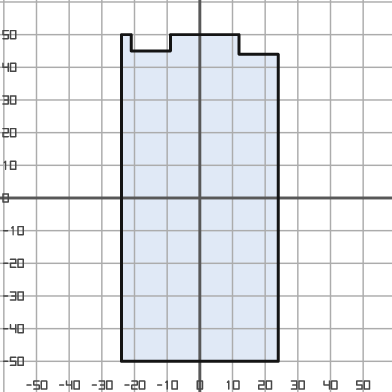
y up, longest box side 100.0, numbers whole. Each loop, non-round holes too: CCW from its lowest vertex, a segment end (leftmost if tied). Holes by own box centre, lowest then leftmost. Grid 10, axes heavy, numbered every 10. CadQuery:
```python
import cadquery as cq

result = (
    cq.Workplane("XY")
    .moveTo(-24.0, -50.0)
    .lineTo(24.0, -50.0)
    .lineTo(24.0, 44.0)
    .lineTo(12.0, 44.0)
    .lineTo(12.0, 50.0)
    .lineTo(-9.0, 50.0)
    .lineTo(-9.0, 45.0)
    .lineTo(-21.0, 45.0)
    .lineTo(-21.0, 50.0)
    .lineTo(-24.0, 50.0)
    .close()
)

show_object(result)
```